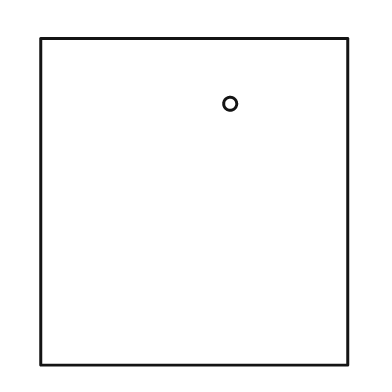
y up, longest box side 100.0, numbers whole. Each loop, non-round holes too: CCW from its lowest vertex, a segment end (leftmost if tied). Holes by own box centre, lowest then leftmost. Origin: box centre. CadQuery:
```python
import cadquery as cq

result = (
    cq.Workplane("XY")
    .moveTo(-47.0, -50.0)
    .lineTo(47.0, -50.0)
    .lineTo(47.0, 50.0)
    .lineTo(-47.0, 50.0)
    .close()
    .moveTo(11.0, 30.0)
    .circle(2.0)
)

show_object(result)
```